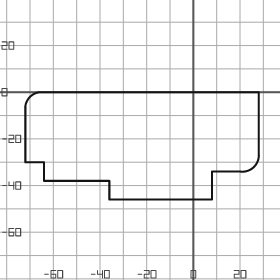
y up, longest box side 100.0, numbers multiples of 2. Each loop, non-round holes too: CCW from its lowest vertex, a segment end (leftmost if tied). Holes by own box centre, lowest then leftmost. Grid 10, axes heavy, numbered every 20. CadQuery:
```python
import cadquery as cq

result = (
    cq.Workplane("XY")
    .moveTo(-36.0, -46.0)
    .lineTo(8.0, -46.0)
    .lineTo(8.0, -34.0)
    .lineTo(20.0, -34.0)
    .threePointArc((26.0, -32.0), (28.0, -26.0))
    .lineTo(28.0, 0.0)
    .lineTo(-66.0, 0.0)
    .threePointArc((-70.0, -2.0), (-72.0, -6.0))
    .lineTo(-72.0, -30.0)
    .lineTo(-64.0, -30.0)
    .lineTo(-64.0, -38.0)
    .lineTo(-36.0, -38.0)
    .close()
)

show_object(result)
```